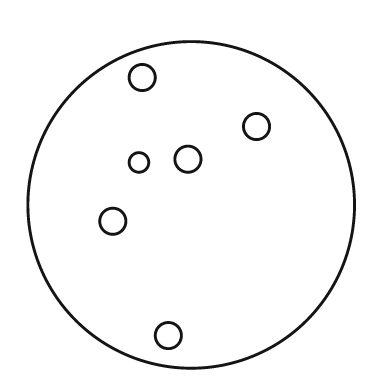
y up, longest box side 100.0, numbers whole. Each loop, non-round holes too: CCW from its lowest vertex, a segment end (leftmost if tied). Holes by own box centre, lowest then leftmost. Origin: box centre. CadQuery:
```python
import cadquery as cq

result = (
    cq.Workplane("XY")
    .moveTo(0.0, 0.0)
    .circle(50.0)
    .moveTo(-7.0, -40.0)
    .circle(4.0)
    .moveTo(-24.0, -5.0)
    .circle(4.0)
    .moveTo(-16.0, 13.0)
    .circle(3.0)
    .moveTo(-1.0, 14.0)
    .circle(4.0)
    .moveTo(20.0, 24.0)
    .circle(4.0)
    .moveTo(-15.0, 39.0)
    .circle(4.0)
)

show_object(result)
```